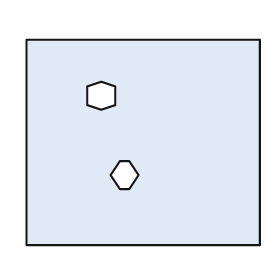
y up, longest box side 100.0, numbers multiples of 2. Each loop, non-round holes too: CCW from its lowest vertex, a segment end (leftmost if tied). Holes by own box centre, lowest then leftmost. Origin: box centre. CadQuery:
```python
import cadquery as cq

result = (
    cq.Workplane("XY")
    .moveTo(-50.0, -44.0)
    .lineTo(50.0, -44.0)
    .lineTo(50.0, 44.0)
    .lineTo(-50.0, 44.0)
    .close()
    .moveTo(-10.0, -20.0)
    .lineTo(-6.0, -20.0)
    .lineTo(-2.0, -14.0)
    .lineTo(-6.0, -8.0)
    .lineTo(-10.0, -8.0)
    .lineTo(-14.0, -14.0)
    .close()
    .moveTo(-18.0, 14.0)
    .lineTo(-12.0, 16.0)
    .lineTo(-12.0, 24.0)
    .lineTo(-18.0, 26.0)
    .lineTo(-24.0, 24.0)
    .lineTo(-24.0, 16.0)
    .close()
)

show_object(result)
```